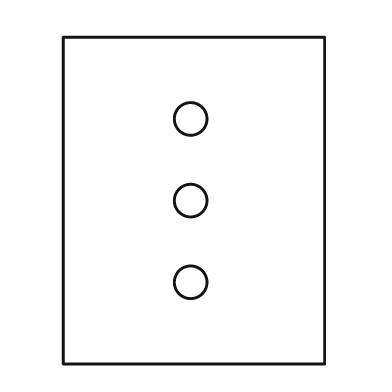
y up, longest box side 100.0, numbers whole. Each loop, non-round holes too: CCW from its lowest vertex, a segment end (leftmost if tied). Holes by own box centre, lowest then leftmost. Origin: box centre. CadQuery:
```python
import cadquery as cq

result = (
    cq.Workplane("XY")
    .moveTo(-40.0, -50.0)
    .lineTo(40.0, -50.0)
    .lineTo(40.0, 50.0)
    .lineTo(-40.0, 50.0)
    .close()
    .moveTo(-1.0, -25.0)
    .circle(5.0)
    .moveTo(-1.0, 0.0)
    .circle(5.0)
    .moveTo(-1.0, 25.0)
    .circle(5.0)
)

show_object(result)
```